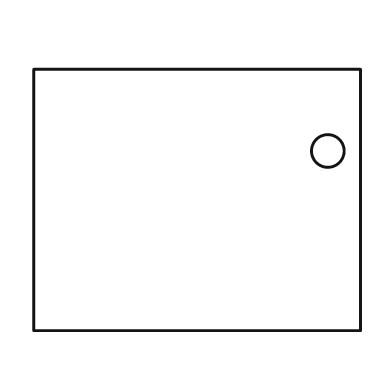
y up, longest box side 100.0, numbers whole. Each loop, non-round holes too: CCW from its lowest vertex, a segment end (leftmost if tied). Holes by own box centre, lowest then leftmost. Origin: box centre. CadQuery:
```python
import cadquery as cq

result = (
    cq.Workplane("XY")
    .moveTo(-50.0, -40.0)
    .lineTo(50.0, -40.0)
    .lineTo(50.0, 40.0)
    .lineTo(-50.0, 40.0)
    .close()
    .moveTo(40.0, 15.0)
    .circle(5.0)
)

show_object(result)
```